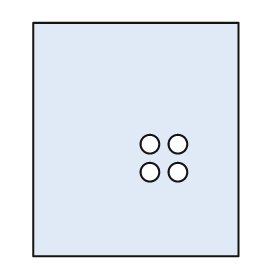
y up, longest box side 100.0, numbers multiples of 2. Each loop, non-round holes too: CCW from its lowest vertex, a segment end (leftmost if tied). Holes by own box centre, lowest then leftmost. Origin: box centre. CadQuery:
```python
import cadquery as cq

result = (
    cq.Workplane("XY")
    .moveTo(-44.0, -50.0)
    .lineTo(44.0, -50.0)
    .lineTo(44.0, 50.0)
    .lineTo(-44.0, 50.0)
    .close()
    .moveTo(6.0, -14.0)
    .circle(4.0)
    .moveTo(18.0, -14.0)
    .circle(4.0)
    .moveTo(6.0, -2.0)
    .circle(4.0)
    .moveTo(18.0, -2.0)
    .circle(4.0)
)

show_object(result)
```